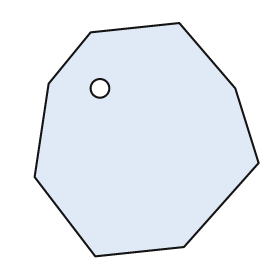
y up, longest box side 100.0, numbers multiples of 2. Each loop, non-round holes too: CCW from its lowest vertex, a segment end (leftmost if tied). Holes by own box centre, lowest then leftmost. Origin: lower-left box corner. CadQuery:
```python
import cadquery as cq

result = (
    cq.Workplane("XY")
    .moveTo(26.0, 0.0)
    .lineTo(64.0, 4.0)
    .lineTo(96.0, 40.0)
    .lineTo(86.0, 72.0)
    .lineTo(62.0, 100.0)
    .lineTo(24.0, 96.0)
    .lineTo(6.0, 74.0)
    .lineTo(0.0, 34.0)
    .close()
    .moveTo(28.0, 72.0)
    .circle(4.0)
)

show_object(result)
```